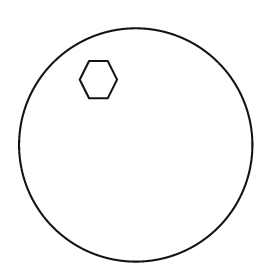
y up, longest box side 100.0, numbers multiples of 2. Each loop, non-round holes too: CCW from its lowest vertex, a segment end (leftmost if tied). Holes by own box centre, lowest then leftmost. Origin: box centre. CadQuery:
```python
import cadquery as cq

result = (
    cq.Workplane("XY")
    .moveTo(0.0, 0.0)
    .circle(50.0)
    .moveTo(-20.0, 20.0)
    .lineTo(-12.0, 20.0)
    .lineTo(-8.0, 28.0)
    .lineTo(-12.0, 36.0)
    .lineTo(-20.0, 36.0)
    .lineTo(-24.0, 28.0)
    .close()
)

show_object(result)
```